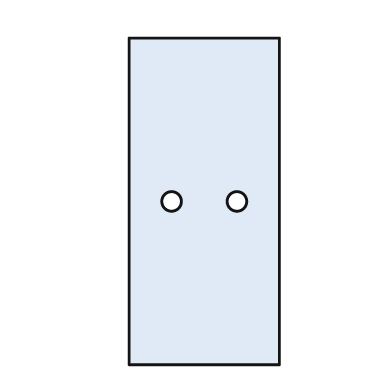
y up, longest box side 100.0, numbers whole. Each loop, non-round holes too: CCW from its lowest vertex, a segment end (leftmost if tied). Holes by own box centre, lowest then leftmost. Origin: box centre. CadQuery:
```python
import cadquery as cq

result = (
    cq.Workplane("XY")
    .moveTo(-23.0, -50.0)
    .lineTo(23.0, -50.0)
    .lineTo(23.0, 50.0)
    .lineTo(-23.0, 50.0)
    .close()
    .moveTo(-10.0, 0.0)
    .circle(3.0)
    .moveTo(10.0, 0.0)
    .circle(3.0)
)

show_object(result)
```